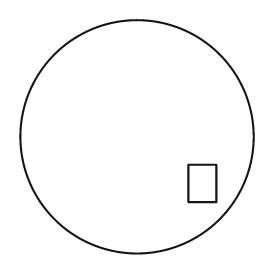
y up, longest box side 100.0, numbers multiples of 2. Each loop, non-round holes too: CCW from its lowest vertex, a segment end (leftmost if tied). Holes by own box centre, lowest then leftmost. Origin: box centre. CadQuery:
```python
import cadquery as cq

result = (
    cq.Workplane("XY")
    .moveTo(0.0, 0.0)
    .circle(50.0)
    .moveTo(22.0, -28.0)
    .lineTo(34.0, -28.0)
    .lineTo(34.0, -12.0)
    .lineTo(22.0, -12.0)
    .close()
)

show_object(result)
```